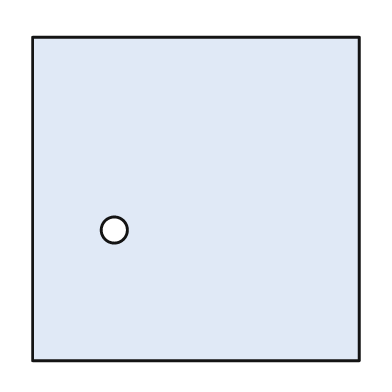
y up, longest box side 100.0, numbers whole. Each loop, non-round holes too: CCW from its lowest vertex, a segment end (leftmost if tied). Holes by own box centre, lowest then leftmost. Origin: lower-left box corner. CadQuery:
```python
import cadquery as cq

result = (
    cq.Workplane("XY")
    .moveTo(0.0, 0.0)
    .lineTo(100.0, 0.0)
    .lineTo(100.0, 99.0)
    .lineTo(0.0, 99.0)
    .close()
    .moveTo(25.0, 40.0)
    .circle(4.0)
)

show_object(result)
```